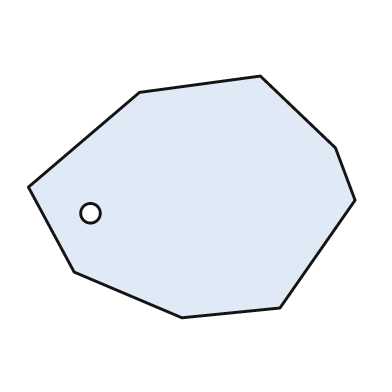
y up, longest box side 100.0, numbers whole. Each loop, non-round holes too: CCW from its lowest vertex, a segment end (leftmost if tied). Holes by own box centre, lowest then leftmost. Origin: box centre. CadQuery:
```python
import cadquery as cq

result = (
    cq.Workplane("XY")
    .moveTo(-3.0, -37.0)
    .lineTo(27.0, -34.0)
    .lineTo(50.0, -1.0)
    .lineTo(44.0, 15.0)
    .lineTo(21.0, 37.0)
    .lineTo(-16.0, 32.0)
    .lineTo(-50.0, 3.0)
    .lineTo(-36.0, -23.0)
    .close()
    .moveTo(-31.0, -5.0)
    .circle(3.0)
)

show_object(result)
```